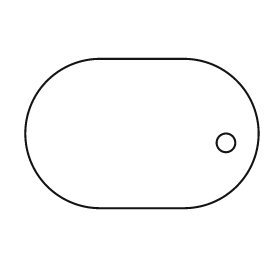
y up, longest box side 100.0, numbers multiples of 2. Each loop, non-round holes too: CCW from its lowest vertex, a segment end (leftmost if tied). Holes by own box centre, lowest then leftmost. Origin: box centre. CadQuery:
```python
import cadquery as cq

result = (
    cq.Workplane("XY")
    .moveTo(-18.0, -32.0)
    .lineTo(18.0, -32.0)
    .threePointArc((50.0, 0.0), (18.0, 32.0))
    .lineTo(-18.0, 32.0)
    .threePointArc((-50.0, 0.0), (-18.0, -32.0))
    .close()
    .moveTo(36.0, -4.0)
    .circle(4.0)
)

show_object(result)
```